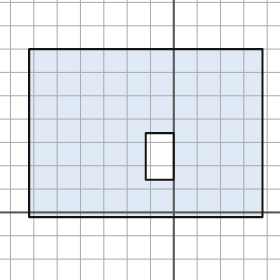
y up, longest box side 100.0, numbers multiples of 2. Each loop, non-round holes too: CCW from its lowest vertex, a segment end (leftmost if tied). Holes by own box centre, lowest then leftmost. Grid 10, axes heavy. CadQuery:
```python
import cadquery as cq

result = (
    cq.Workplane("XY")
    .moveTo(-62.0, -2.0)
    .lineTo(38.0, -2.0)
    .lineTo(38.0, 70.0)
    .lineTo(-62.0, 70.0)
    .close()
    .moveTo(-12.0, 14.0)
    .lineTo(0.0, 14.0)
    .lineTo(0.0, 34.0)
    .lineTo(-12.0, 34.0)
    .close()
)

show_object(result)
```